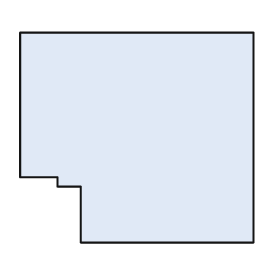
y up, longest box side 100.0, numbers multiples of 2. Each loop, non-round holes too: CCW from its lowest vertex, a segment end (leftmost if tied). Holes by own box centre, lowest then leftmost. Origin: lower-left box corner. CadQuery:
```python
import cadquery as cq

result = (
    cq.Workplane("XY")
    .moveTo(26.0, 0.0)
    .lineTo(100.0, 0.0)
    .lineTo(100.0, 90.0)
    .lineTo(0.0, 90.0)
    .lineTo(0.0, 28.0)
    .lineTo(16.0, 28.0)
    .lineTo(16.0, 24.0)
    .lineTo(26.0, 24.0)
    .close()
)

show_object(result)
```